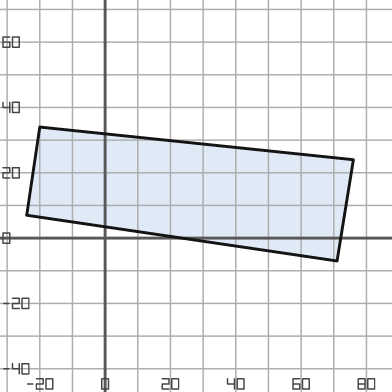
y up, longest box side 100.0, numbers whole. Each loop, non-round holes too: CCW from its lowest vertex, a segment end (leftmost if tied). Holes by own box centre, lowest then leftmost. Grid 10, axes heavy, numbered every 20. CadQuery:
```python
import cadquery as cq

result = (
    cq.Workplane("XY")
    .moveTo(71.0, -7.0)
    .lineTo(76.0, 24.0)
    .lineTo(-20.0, 34.0)
    .lineTo(-24.0, 7.0)
    .close()
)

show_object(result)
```